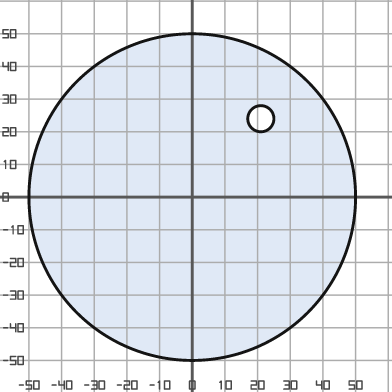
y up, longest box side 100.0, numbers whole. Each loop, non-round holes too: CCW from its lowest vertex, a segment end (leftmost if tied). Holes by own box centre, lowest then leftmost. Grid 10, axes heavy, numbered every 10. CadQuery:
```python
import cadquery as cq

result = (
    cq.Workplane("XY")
    .moveTo(0.0, 0.0)
    .circle(50.0)
    .moveTo(21.0, 24.0)
    .circle(4.0)
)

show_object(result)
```